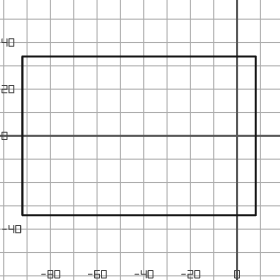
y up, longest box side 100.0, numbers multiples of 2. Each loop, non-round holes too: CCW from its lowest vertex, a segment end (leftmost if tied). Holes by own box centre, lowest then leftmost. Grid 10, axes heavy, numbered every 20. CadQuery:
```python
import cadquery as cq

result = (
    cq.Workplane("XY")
    .moveTo(-92.0, -34.0)
    .lineTo(8.0, -34.0)
    .lineTo(8.0, 34.0)
    .lineTo(-92.0, 34.0)
    .close()
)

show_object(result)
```